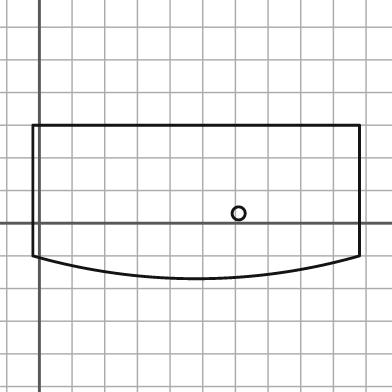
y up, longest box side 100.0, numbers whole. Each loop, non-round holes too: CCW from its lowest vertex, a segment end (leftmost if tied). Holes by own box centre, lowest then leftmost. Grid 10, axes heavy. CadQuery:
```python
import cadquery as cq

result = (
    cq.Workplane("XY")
    .moveTo(-2.0, -10.0)
    .threePointArc((48.0, -17.0), (98.0, -10.0))
    .lineTo(98.0, 30.0)
    .lineTo(-2.0, 30.0)
    .close()
    .moveTo(61.0, 3.0)
    .circle(2.0)
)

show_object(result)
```